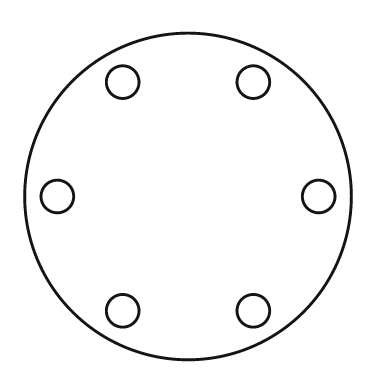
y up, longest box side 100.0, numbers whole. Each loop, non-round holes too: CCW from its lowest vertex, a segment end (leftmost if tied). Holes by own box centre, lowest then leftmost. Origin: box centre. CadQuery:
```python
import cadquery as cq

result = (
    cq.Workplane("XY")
    .moveTo(0.0, 0.0)
    .circle(50.0)
    .moveTo(-20.0, -35.0)
    .circle(5.0)
    .moveTo(20.0, -35.0)
    .circle(5.0)
    .moveTo(-40.0, 0.0)
    .circle(5.0)
    .moveTo(40.0, 0.0)
    .circle(5.0)
    .moveTo(-20.0, 35.0)
    .circle(5.0)
    .moveTo(20.0, 35.0)
    .circle(5.0)
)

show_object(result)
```